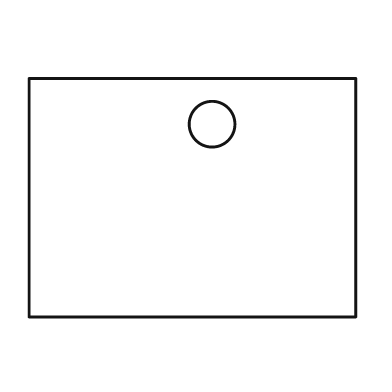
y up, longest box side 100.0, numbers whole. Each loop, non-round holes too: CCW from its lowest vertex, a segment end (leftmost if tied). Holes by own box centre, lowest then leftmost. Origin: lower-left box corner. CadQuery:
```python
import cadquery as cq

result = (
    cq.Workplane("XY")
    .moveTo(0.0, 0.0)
    .lineTo(100.0, 0.0)
    .lineTo(100.0, 73.0)
    .lineTo(0.0, 73.0)
    .close()
    .moveTo(56.0, 59.0)
    .circle(7.0)
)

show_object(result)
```